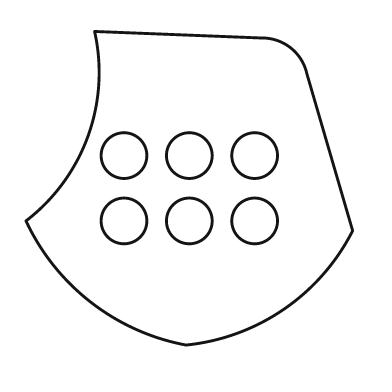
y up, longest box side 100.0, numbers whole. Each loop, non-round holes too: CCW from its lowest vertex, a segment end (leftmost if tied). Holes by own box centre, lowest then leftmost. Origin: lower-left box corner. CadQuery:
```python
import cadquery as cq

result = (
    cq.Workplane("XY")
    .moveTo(49.0, 0.0)
    .threePointArc((79.0, 11.0), (100.0, 35.0))
    .lineTo(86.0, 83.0)
    .threePointArc((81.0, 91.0), (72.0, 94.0))
    .lineTo(21.0, 96.0)
    .threePointArc((19.0, 64.0), (0.0, 38.0))
    .threePointArc((20.0, 13.0), (49.0, 0.0))
    .close()
    .moveTo(30.0, 38.0)
    .circle(7.0)
    .moveTo(50.0, 38.0)
    .circle(7.0)
    .moveTo(70.0, 38.0)
    .circle(7.0)
    .moveTo(30.0, 58.0)
    .circle(7.0)
    .moveTo(50.0, 58.0)
    .circle(7.0)
    .moveTo(70.0, 58.0)
    .circle(7.0)
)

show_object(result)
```